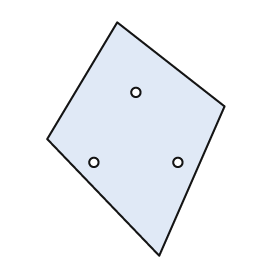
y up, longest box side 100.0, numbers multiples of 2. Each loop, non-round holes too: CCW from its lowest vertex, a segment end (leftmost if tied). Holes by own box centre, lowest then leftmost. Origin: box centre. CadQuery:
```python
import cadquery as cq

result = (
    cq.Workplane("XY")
    .moveTo(10.0, -50.0)
    .lineTo(38.0, 14.0)
    .lineTo(-8.0, 50.0)
    .lineTo(-38.0, 0.0)
    .close()
    .moveTo(-18.0, -10.0)
    .circle(2.0)
    .moveTo(18.0, -10.0)
    .circle(2.0)
    .moveTo(0.0, 20.0)
    .circle(2.0)
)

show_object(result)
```